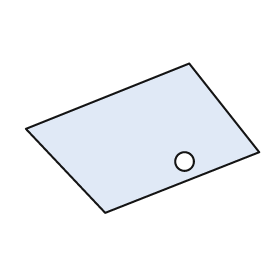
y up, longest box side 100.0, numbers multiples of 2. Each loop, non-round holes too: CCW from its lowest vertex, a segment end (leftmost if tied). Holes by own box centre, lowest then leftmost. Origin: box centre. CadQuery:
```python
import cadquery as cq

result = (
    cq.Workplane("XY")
    .moveTo(-16.0, -32.0)
    .lineTo(50.0, -6.0)
    .lineTo(20.0, 32.0)
    .lineTo(-50.0, 4.0)
    .close()
    .moveTo(18.0, -10.0)
    .circle(4.0)
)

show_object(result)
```